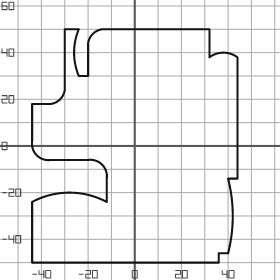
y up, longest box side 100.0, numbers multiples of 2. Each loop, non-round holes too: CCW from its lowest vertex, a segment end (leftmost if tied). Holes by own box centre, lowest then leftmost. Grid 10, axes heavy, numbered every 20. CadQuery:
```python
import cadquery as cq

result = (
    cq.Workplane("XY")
    .moveTo(-44.0, -50.0)
    .lineTo(36.0, -50.0)
    .lineTo(36.0, -46.0)
    .lineTo(40.0, -46.0)
    .threePointArc((42.0, -30.0), (40.0, -14.0))
    .lineTo(44.0, -14.0)
    .lineTo(44.0, 38.0)
    .threePointArc((38.0, 40.0), (32.0, 38.0))
    .lineTo(32.0, 50.0)
    .lineTo(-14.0, 50.0)
    .threePointArc((-18.0, 48.0), (-20.0, 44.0))
    .lineTo(-20.0, 30.0)
    .lineTo(-24.0, 30.0)
    .threePointArc((-26.0, 40.0), (-24.0, 50.0))
    .lineTo(-30.0, 50.0)
    .lineTo(-30.0, 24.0)
    .threePointArc((-32.0, 20.0), (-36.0, 18.0))
    .lineTo(-44.0, 18.0)
    .lineTo(-44.0, 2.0)
    .threePointArc((-42.0, -4.0), (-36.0, -6.0))
    .lineTo(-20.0, -6.0)
    .threePointArc((-14.0, -8.0), (-12.0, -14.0))
    .lineTo(-12.0, -24.0)
    .threePointArc((-28.0, -20.0), (-44.0, -24.0))
    .close()
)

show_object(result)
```